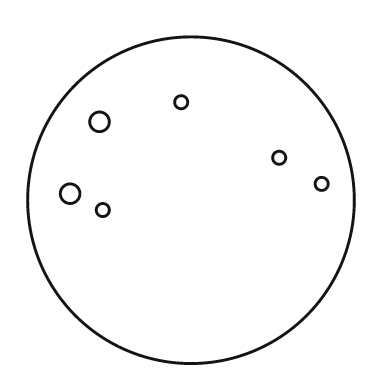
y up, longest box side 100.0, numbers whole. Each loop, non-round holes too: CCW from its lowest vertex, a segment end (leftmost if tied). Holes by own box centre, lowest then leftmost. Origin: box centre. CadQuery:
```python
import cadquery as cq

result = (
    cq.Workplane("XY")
    .moveTo(0.0, 0.0)
    .circle(50.0)
    .moveTo(-27.0, -3.0)
    .circle(2.0)
    .moveTo(-37.0, 2.0)
    .circle(3.0)
    .moveTo(40.0, 5.0)
    .circle(2.0)
    .moveTo(27.0, 13.0)
    .circle(2.0)
    .moveTo(-28.0, 24.0)
    .circle(3.0)
    .moveTo(-3.0, 30.0)
    .circle(2.0)
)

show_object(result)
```